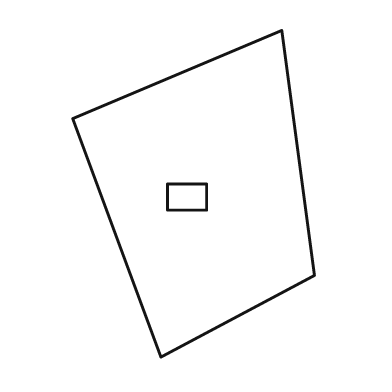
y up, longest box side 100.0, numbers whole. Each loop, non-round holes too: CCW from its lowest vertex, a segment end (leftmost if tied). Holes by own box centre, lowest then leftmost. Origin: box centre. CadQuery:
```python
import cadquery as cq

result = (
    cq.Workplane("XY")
    .moveTo(-10.0, -50.0)
    .lineTo(37.0, -25.0)
    .lineTo(27.0, 50.0)
    .lineTo(-37.0, 23.0)
    .close()
    .moveTo(-8.0, -5.0)
    .lineTo(4.0, -5.0)
    .lineTo(4.0, 3.0)
    .lineTo(-8.0, 3.0)
    .close()
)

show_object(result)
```